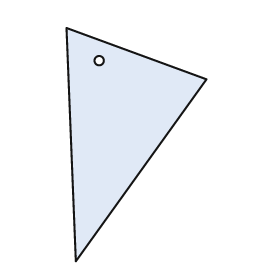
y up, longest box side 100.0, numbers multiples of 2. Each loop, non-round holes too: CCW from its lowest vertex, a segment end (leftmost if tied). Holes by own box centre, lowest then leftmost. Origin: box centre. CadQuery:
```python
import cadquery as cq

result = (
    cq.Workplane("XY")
    .moveTo(-26.0, -50.0)
    .lineTo(30.0, 28.0)
    .lineTo(-30.0, 50.0)
    .close()
    .moveTo(-16.0, 36.0)
    .circle(2.0)
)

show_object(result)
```